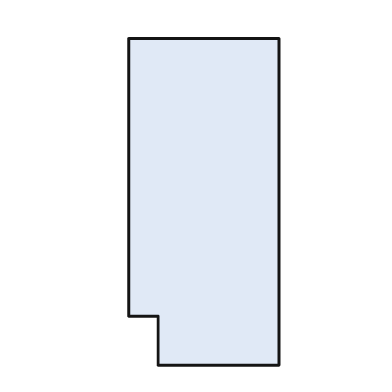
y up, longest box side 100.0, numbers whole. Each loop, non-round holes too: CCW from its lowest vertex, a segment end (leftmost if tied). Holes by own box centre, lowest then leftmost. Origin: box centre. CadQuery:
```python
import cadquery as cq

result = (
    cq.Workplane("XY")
    .moveTo(-14.0, -50.0)
    .lineTo(23.0, -50.0)
    .lineTo(23.0, 50.0)
    .lineTo(-23.0, 50.0)
    .lineTo(-23.0, -35.0)
    .lineTo(-14.0, -35.0)
    .close()
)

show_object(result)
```